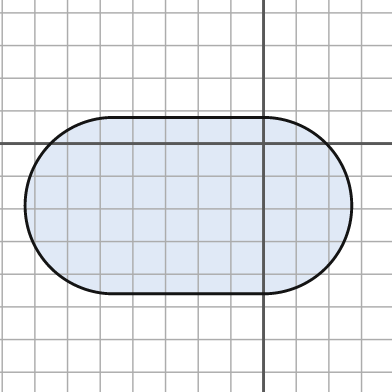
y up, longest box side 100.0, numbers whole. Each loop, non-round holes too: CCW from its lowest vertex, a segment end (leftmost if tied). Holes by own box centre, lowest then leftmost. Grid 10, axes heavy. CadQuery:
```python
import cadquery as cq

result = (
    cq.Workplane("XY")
    .moveTo(-46.0, -46.0)
    .lineTo(0.0, -46.0)
    .threePointArc((27.0, -19.0), (0.0, 8.0))
    .lineTo(-46.0, 8.0)
    .threePointArc((-73.0, -19.0), (-46.0, -46.0))
    .close()
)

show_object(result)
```